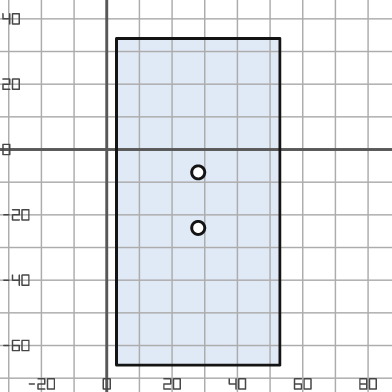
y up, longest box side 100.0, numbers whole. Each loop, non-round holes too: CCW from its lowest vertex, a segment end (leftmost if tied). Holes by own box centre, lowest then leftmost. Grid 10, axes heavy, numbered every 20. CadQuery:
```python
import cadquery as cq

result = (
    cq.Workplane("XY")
    .moveTo(3.0, -66.0)
    .lineTo(53.0, -66.0)
    .lineTo(53.0, 34.0)
    .lineTo(3.0, 34.0)
    .close()
    .moveTo(28.0, -24.0)
    .circle(2.0)
    .moveTo(28.0, -7.0)
    .circle(2.0)
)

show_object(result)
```